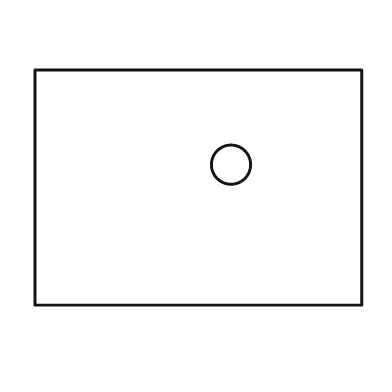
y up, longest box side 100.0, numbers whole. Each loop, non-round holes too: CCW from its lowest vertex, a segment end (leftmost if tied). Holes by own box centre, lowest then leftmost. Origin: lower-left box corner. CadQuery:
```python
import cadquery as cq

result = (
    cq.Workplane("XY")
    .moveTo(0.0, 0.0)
    .lineTo(100.0, 0.0)
    .lineTo(100.0, 72.0)
    .lineTo(0.0, 72.0)
    .close()
    .moveTo(60.0, 43.0)
    .circle(6.0)
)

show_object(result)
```